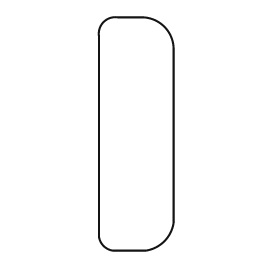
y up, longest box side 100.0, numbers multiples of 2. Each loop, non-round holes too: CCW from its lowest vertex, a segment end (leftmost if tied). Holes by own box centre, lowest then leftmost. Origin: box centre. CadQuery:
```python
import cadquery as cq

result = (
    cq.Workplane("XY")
    .moveTo(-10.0, -50.0)
    .lineTo(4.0, -50.0)
    .threePointArc((12.0, -46.0), (16.0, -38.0))
    .lineTo(16.0, 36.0)
    .threePointArc((12.0, 46.0), (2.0, 50.0))
    .lineTo(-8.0, 50.0)
    .threePointArc((-14.0, 48.0), (-16.0, 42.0))
    .lineTo(-16.0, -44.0)
    .threePointArc((-14.0, -48.0), (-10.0, -50.0))
    .close()
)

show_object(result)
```